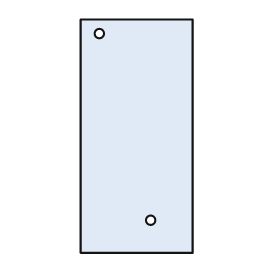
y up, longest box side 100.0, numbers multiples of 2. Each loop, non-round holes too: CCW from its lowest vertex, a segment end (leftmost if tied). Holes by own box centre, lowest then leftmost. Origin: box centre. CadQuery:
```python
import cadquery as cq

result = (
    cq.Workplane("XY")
    .moveTo(-24.0, -50.0)
    .lineTo(24.0, -50.0)
    .lineTo(24.0, 50.0)
    .lineTo(-24.0, 50.0)
    .close()
    .moveTo(6.0, -36.0)
    .circle(2.0)
    .moveTo(-16.0, 44.0)
    .circle(2.0)
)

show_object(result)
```